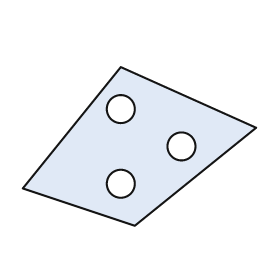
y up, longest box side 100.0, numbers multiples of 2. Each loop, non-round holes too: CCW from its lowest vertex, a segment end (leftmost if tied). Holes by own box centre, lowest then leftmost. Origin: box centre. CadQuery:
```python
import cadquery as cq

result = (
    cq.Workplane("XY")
    .moveTo(-2.0, -34.0)
    .lineTo(50.0, 8.0)
    .lineTo(-8.0, 34.0)
    .lineTo(-50.0, -18.0)
    .close()
    .moveTo(-8.0, -16.0)
    .circle(6.0)
    .moveTo(18.0, 0.0)
    .circle(6.0)
    .moveTo(-8.0, 16.0)
    .circle(6.0)
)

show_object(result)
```